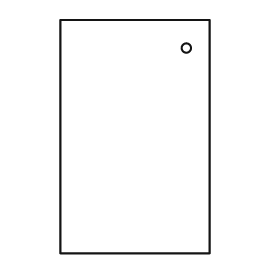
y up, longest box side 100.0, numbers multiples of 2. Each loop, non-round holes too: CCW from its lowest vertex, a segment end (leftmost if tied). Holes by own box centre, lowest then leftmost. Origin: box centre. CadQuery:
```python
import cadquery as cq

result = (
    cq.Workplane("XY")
    .moveTo(-32.0, -50.0)
    .lineTo(32.0, -50.0)
    .lineTo(32.0, 50.0)
    .lineTo(-32.0, 50.0)
    .close()
    .moveTo(22.0, 38.0)
    .circle(2.0)
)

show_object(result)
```